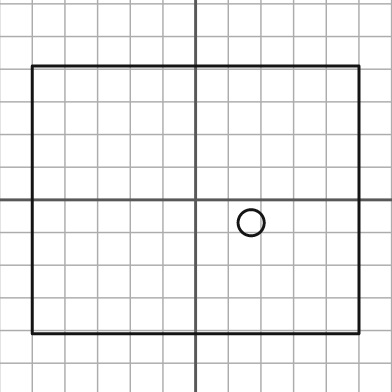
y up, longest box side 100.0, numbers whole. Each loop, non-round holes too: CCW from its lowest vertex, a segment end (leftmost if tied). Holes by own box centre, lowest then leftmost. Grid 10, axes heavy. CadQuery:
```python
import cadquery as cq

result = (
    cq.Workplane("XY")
    .moveTo(-50.0, -41.0)
    .lineTo(50.0, -41.0)
    .lineTo(50.0, 41.0)
    .lineTo(-50.0, 41.0)
    .close()
    .moveTo(17.0, -7.0)
    .circle(4.0)
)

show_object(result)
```